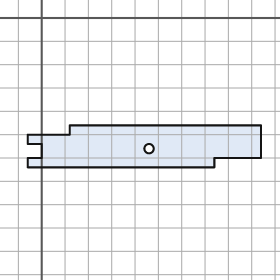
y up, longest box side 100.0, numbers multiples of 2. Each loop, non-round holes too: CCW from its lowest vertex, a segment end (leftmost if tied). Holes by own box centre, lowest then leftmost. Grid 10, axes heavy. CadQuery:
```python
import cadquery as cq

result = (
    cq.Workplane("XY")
    .moveTo(-6.0, -64.0)
    .lineTo(74.0, -64.0)
    .lineTo(74.0, -60.0)
    .lineTo(94.0, -60.0)
    .lineTo(94.0, -46.0)
    .lineTo(12.0, -46.0)
    .lineTo(12.0, -50.0)
    .lineTo(-6.0, -50.0)
    .lineTo(-6.0, -54.0)
    .lineTo(0.0, -54.0)
    .lineTo(0.0, -60.0)
    .lineTo(-6.0, -60.0)
    .close()
    .moveTo(46.0, -56.0)
    .circle(2.0)
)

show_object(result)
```